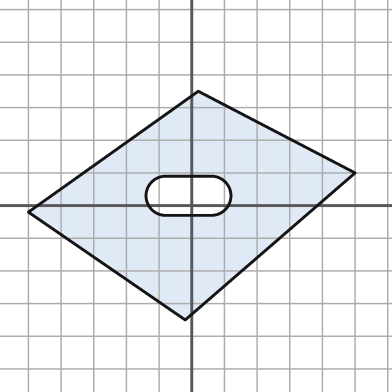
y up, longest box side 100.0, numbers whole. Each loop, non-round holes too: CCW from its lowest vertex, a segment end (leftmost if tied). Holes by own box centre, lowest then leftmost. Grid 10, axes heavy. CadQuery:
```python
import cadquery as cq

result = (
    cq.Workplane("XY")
    .moveTo(-2.0, -35.0)
    .lineTo(50.0, 10.0)
    .lineTo(2.0, 35.0)
    .lineTo(-50.0, -2.0)
    .close()
    .moveTo(-8.0, -3.0)
    .lineTo(6.0, -3.0)
    .threePointArc((12.0, 3.0), (6.0, 9.0))
    .lineTo(-8.0, 9.0)
    .threePointArc((-14.0, 3.0), (-8.0, -3.0))
    .close()
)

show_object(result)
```